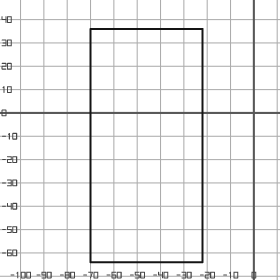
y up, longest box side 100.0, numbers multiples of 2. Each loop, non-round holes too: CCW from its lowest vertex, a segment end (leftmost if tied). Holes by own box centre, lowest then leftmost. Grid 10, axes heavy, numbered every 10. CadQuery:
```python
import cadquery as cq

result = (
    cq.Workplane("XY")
    .moveTo(-70.0, -64.0)
    .lineTo(-22.0, -64.0)
    .lineTo(-22.0, 36.0)
    .lineTo(-70.0, 36.0)
    .close()
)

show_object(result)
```